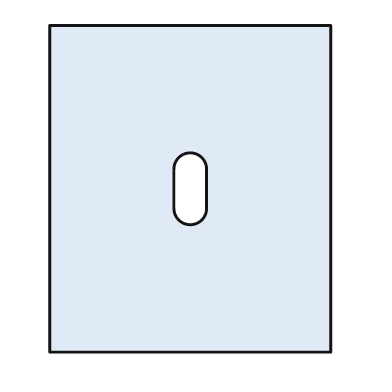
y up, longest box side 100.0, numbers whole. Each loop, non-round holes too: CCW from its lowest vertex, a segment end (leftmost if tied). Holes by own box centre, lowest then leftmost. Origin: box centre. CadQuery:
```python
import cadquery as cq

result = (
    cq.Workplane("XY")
    .moveTo(-43.0, -50.0)
    .lineTo(43.0, -50.0)
    .lineTo(43.0, 50.0)
    .lineTo(-43.0, 50.0)
    .close()
    .moveTo(-5.0, -6.0)
    .threePointArc((0.0, -11.0), (5.0, -6.0))
    .lineTo(5.0, 6.0)
    .threePointArc((0.0, 11.0), (-5.0, 6.0))
    .close()
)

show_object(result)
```